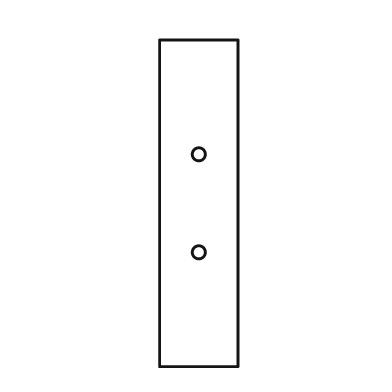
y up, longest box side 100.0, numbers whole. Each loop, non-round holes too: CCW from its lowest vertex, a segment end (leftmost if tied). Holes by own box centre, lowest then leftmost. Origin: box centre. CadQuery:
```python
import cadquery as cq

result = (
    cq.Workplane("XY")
    .moveTo(-12.0, -50.0)
    .lineTo(12.0, -50.0)
    .lineTo(12.0, 50.0)
    .lineTo(-12.0, 50.0)
    .close()
    .moveTo(0.0, -15.0)
    .circle(2.0)
    .moveTo(0.0, 15.0)
    .circle(2.0)
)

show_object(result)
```